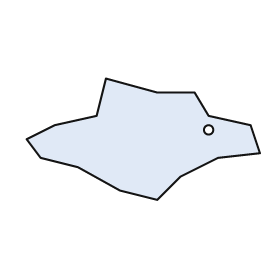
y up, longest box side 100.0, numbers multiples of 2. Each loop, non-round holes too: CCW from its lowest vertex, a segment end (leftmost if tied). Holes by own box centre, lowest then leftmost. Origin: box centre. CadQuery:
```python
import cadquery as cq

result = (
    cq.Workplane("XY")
    .moveTo(6.0, -26.0)
    .lineTo(16.0, -16.0)
    .lineTo(32.0, -8.0)
    .lineTo(50.0, -6.0)
    .lineTo(46.0, 6.0)
    .lineTo(28.0, 10.0)
    .lineTo(22.0, 20.0)
    .lineTo(6.0, 20.0)
    .lineTo(-16.0, 26.0)
    .lineTo(-20.0, 10.0)
    .lineTo(-38.0, 6.0)
    .lineTo(-50.0, 0.0)
    .lineTo(-44.0, -8.0)
    .lineTo(-28.0, -12.0)
    .lineTo(-10.0, -22.0)
    .close()
    .moveTo(28.0, 4.0)
    .circle(2.0)
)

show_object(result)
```